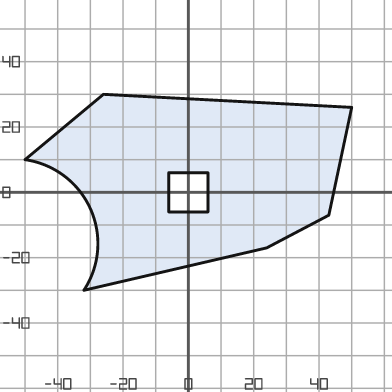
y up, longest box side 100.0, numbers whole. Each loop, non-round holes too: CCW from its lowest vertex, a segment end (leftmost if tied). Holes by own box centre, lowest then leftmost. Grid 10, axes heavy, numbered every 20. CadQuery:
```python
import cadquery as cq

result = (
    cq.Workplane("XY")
    .moveTo(-32.0, -30.0)
    .lineTo(24.0, -17.0)
    .lineTo(43.0, -7.0)
    .lineTo(50.0, 26.0)
    .lineTo(-26.0, 30.0)
    .lineTo(-50.0, 10.0)
    .threePointArc((-30.0, -5.0), (-32.0, -30.0))
    .close()
    .moveTo(-6.0, -6.0)
    .lineTo(6.0, -6.0)
    .lineTo(6.0, 6.0)
    .lineTo(-6.0, 6.0)
    .close()
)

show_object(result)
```